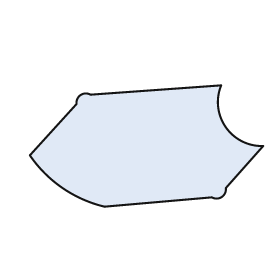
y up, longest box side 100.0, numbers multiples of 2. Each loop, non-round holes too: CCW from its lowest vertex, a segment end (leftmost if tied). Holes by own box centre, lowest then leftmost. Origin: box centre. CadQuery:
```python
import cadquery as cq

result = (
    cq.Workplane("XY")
    .moveTo(-18.0, -26.0)
    .lineTo(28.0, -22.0)
    .threePointArc((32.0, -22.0), (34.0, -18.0))
    .lineTo(50.0, 0.0)
    .threePointArc((34.0, 8.0), (32.0, 26.0))
    .lineTo(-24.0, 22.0)
    .threePointArc((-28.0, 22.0), (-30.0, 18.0))
    .lineTo(-50.0, -4.0)
    .threePointArc((-36.0, -18.0), (-18.0, -26.0))
    .close()
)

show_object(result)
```